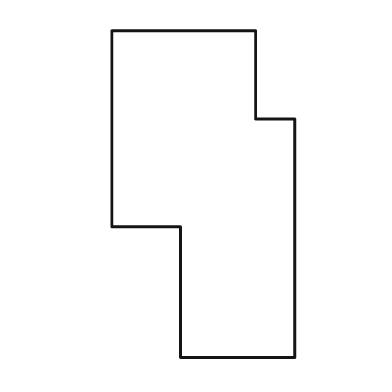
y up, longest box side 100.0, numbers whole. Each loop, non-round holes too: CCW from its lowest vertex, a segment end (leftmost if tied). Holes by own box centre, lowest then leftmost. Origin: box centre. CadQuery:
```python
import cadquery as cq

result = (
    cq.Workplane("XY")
    .moveTo(-7.0, -50.0)
    .lineTo(28.0, -50.0)
    .lineTo(28.0, 23.0)
    .lineTo(16.0, 23.0)
    .lineTo(16.0, 50.0)
    .lineTo(-28.0, 50.0)
    .lineTo(-28.0, -10.0)
    .lineTo(-7.0, -10.0)
    .close()
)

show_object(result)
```